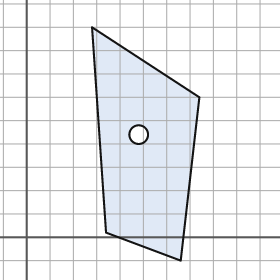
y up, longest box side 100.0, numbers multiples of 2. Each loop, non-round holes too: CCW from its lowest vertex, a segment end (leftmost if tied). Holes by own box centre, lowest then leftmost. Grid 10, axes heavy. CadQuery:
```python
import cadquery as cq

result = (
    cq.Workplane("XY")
    .moveTo(66.0, -10.0)
    .lineTo(74.0, 60.0)
    .lineTo(28.0, 90.0)
    .lineTo(34.0, 2.0)
    .close()
    .moveTo(48.0, 44.0)
    .circle(4.0)
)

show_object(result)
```